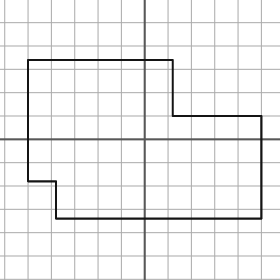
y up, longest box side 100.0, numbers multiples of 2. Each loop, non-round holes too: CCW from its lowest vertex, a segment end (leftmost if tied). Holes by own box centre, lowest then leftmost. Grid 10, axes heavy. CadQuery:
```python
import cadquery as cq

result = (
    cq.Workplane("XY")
    .moveTo(-38.0, -34.0)
    .lineTo(50.0, -34.0)
    .lineTo(50.0, 10.0)
    .lineTo(12.0, 10.0)
    .lineTo(12.0, 34.0)
    .lineTo(-50.0, 34.0)
    .lineTo(-50.0, -18.0)
    .lineTo(-38.0, -18.0)
    .close()
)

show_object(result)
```